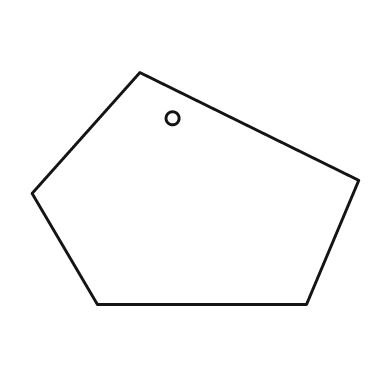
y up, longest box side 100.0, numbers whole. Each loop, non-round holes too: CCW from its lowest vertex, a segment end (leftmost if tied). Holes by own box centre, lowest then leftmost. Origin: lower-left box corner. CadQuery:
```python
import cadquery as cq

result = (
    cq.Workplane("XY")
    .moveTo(20.0, 0.0)
    .lineTo(84.0, 0.0)
    .lineTo(100.0, 38.0)
    .lineTo(33.0, 71.0)
    .lineTo(0.0, 34.0)
    .close()
    .moveTo(43.0, 57.0)
    .circle(2.0)
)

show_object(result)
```